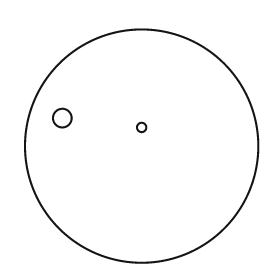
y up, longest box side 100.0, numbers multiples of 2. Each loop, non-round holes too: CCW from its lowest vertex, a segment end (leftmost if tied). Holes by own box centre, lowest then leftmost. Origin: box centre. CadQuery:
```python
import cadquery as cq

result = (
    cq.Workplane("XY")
    .moveTo(0.0, 0.0)
    .circle(50.0)
    .moveTo(0.0, 8.0)
    .circle(2.0)
    .moveTo(-34.0, 12.0)
    .circle(4.0)
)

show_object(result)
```